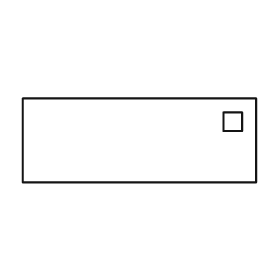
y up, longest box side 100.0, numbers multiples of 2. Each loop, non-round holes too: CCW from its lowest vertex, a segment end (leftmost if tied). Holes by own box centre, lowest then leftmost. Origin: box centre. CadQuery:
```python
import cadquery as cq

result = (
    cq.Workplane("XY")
    .moveTo(-50.0, -18.0)
    .lineTo(50.0, -18.0)
    .lineTo(50.0, 18.0)
    .lineTo(-50.0, 18.0)
    .close()
    .moveTo(36.0, 4.0)
    .lineTo(44.0, 4.0)
    .lineTo(44.0, 12.0)
    .lineTo(36.0, 12.0)
    .close()
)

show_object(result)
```